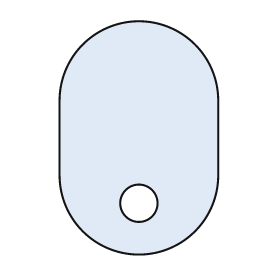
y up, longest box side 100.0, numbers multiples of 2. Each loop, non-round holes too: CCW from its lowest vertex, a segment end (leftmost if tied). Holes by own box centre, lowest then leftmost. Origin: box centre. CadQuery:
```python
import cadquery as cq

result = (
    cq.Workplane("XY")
    .moveTo(-34.0, -16.0)
    .threePointArc((0.0, -50.0), (34.0, -16.0))
    .lineTo(34.0, 16.0)
    .threePointArc((0.0, 50.0), (-34.0, 16.0))
    .close()
    .moveTo(0.0, -28.0)
    .circle(8.0)
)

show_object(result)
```